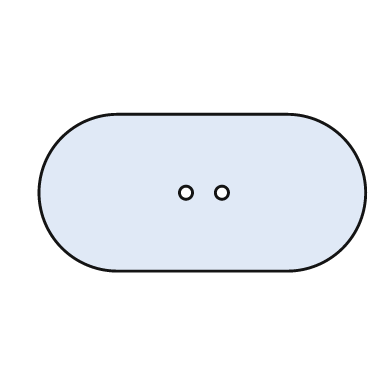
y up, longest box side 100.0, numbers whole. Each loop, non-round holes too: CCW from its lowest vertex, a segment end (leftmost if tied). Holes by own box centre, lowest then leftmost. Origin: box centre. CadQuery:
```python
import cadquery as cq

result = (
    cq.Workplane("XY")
    .moveTo(-26.0, -24.0)
    .lineTo(26.0, -24.0)
    .threePointArc((50.0, 0.0), (26.0, 24.0))
    .lineTo(-26.0, 24.0)
    .threePointArc((-50.0, 0.0), (-26.0, -24.0))
    .close()
    .moveTo(-5.0, 0.0)
    .circle(2.0)
    .moveTo(6.0, 0.0)
    .circle(2.0)
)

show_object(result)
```